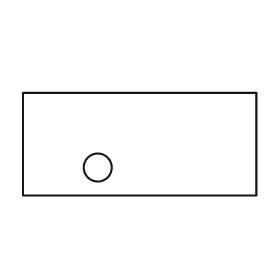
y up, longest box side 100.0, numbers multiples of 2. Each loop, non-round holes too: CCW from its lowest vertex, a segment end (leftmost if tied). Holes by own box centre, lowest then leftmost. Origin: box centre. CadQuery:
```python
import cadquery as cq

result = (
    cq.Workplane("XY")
    .moveTo(-50.0, -22.0)
    .lineTo(50.0, -22.0)
    .lineTo(50.0, 22.0)
    .lineTo(-50.0, 22.0)
    .close()
    .moveTo(-18.0, -10.0)
    .circle(6.0)
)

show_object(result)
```